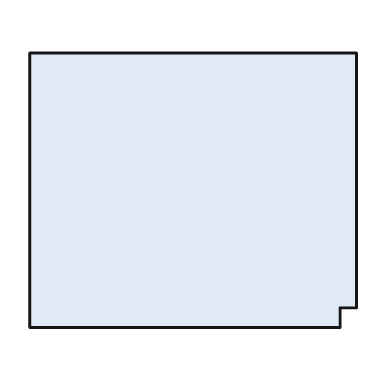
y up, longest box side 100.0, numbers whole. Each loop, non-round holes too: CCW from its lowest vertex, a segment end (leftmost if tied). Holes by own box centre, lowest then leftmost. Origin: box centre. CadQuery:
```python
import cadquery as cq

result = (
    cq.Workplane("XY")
    .moveTo(-50.0, -42.0)
    .lineTo(45.0, -42.0)
    .lineTo(45.0, -36.0)
    .lineTo(50.0, -36.0)
    .lineTo(50.0, 42.0)
    .lineTo(-50.0, 42.0)
    .close()
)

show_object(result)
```